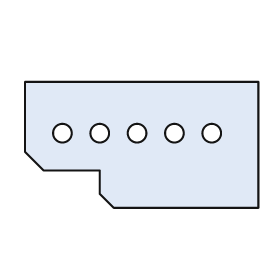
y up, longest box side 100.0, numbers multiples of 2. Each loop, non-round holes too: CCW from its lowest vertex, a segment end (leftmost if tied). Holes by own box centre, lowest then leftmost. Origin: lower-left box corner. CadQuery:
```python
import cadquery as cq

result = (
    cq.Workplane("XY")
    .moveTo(38.0, 0.0)
    .lineTo(100.0, 0.0)
    .lineTo(100.0, 54.0)
    .lineTo(0.0, 54.0)
    .lineTo(0.0, 24.0)
    .lineTo(8.0, 16.0)
    .lineTo(32.0, 16.0)
    .lineTo(32.0, 6.0)
    .close()
    .moveTo(16.0, 32.0)
    .circle(4.0)
    .moveTo(32.0, 32.0)
    .circle(4.0)
    .moveTo(48.0, 32.0)
    .circle(4.0)
    .moveTo(64.0, 32.0)
    .circle(4.0)
    .moveTo(80.0, 32.0)
    .circle(4.0)
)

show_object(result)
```